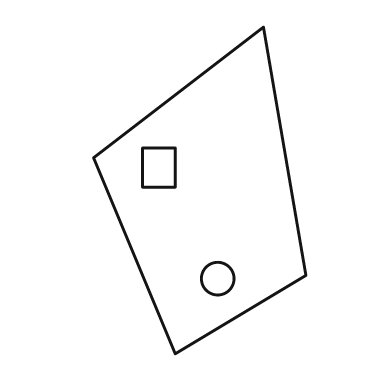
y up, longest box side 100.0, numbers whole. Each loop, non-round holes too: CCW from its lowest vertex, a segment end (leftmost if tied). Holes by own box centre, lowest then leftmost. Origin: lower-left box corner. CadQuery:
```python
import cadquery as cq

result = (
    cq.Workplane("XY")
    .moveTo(25.0, 0.0)
    .lineTo(65.0, 24.0)
    .lineTo(52.0, 100.0)
    .lineTo(0.0, 60.0)
    .close()
    .moveTo(38.0, 23.0)
    .circle(5.0)
    .moveTo(15.0, 51.0)
    .lineTo(25.0, 51.0)
    .lineTo(25.0, 63.0)
    .lineTo(15.0, 63.0)
    .close()
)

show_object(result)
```